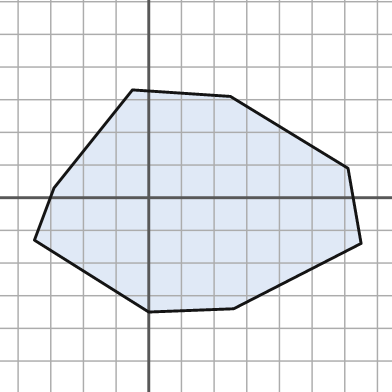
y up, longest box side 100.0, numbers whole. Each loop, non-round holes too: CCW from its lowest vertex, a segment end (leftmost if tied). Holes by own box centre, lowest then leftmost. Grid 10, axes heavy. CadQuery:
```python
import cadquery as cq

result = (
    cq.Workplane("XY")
    .moveTo(0.0, -35.0)
    .lineTo(26.0, -34.0)
    .lineTo(65.0, -14.0)
    .lineTo(61.0, 9.0)
    .lineTo(25.0, 31.0)
    .lineTo(-5.0, 33.0)
    .lineTo(-29.0, 3.0)
    .lineTo(-35.0, -13.0)
    .close()
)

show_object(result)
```